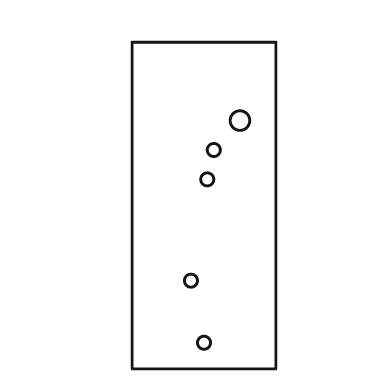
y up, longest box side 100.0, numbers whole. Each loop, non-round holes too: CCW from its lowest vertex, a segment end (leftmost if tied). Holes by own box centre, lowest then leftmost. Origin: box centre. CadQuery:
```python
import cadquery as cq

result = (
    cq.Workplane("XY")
    .moveTo(-22.0, -50.0)
    .lineTo(22.0, -50.0)
    .lineTo(22.0, 50.0)
    .lineTo(-22.0, 50.0)
    .close()
    .moveTo(0.0, -42.0)
    .circle(2.0)
    .moveTo(-4.0, -23.0)
    .circle(2.0)
    .moveTo(1.0, 8.0)
    .circle(2.0)
    .moveTo(3.0, 17.0)
    .circle(2.0)
    .moveTo(11.0, 26.0)
    .circle(3.0)
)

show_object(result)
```